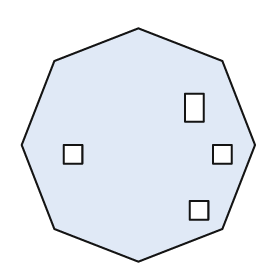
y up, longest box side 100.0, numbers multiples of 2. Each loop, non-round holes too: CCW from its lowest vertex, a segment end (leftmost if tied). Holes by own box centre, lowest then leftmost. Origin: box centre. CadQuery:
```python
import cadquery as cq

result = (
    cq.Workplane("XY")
    .moveTo(0.0, -50.0)
    .lineTo(36.0, -36.0)
    .lineTo(50.0, 0.0)
    .lineTo(36.0, 36.0)
    .lineTo(0.0, 50.0)
    .lineTo(-36.0, 36.0)
    .lineTo(-50.0, 0.0)
    .lineTo(-36.0, -36.0)
    .close()
    .moveTo(22.0, -32.0)
    .lineTo(30.0, -32.0)
    .lineTo(30.0, -24.0)
    .lineTo(22.0, -24.0)
    .close()
    .moveTo(-32.0, -8.0)
    .lineTo(-24.0, -8.0)
    .lineTo(-24.0, 0.0)
    .lineTo(-32.0, 0.0)
    .close()
    .moveTo(32.0, -8.0)
    .lineTo(40.0, -8.0)
    .lineTo(40.0, 0.0)
    .lineTo(32.0, 0.0)
    .close()
    .moveTo(20.0, 10.0)
    .lineTo(28.0, 10.0)
    .lineTo(28.0, 22.0)
    .lineTo(20.0, 22.0)
    .close()
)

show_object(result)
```